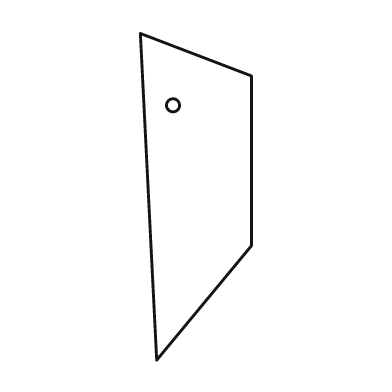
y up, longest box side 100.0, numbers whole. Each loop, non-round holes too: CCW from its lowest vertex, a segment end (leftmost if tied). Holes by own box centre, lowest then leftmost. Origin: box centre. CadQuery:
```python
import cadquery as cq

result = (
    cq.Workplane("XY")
    .moveTo(-12.0, -50.0)
    .lineTo(17.0, -15.0)
    .lineTo(17.0, 37.0)
    .lineTo(-17.0, 50.0)
    .close()
    .moveTo(-7.0, 28.0)
    .circle(2.0)
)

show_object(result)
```